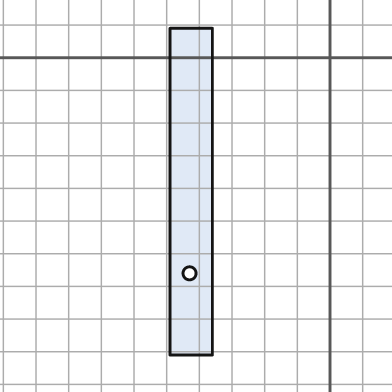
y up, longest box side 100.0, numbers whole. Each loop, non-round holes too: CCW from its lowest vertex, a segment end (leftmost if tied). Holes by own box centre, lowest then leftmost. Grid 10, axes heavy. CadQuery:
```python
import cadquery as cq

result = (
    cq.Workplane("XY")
    .moveTo(-49.0, -91.0)
    .lineTo(-36.0, -91.0)
    .lineTo(-36.0, 9.0)
    .lineTo(-49.0, 9.0)
    .close()
    .moveTo(-43.0, -66.0)
    .circle(2.0)
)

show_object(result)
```